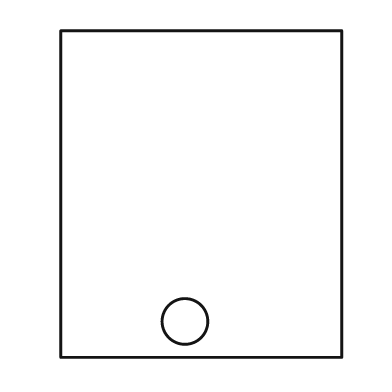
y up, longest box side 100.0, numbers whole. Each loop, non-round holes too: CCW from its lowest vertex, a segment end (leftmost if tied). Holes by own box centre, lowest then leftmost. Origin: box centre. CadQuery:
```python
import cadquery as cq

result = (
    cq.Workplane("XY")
    .moveTo(-43.0, -50.0)
    .lineTo(43.0, -50.0)
    .lineTo(43.0, 50.0)
    .lineTo(-43.0, 50.0)
    .close()
    .moveTo(-5.0, -39.0)
    .circle(7.0)
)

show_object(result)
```